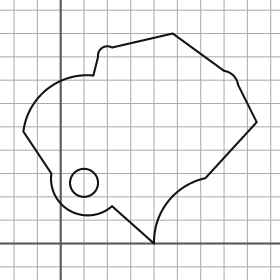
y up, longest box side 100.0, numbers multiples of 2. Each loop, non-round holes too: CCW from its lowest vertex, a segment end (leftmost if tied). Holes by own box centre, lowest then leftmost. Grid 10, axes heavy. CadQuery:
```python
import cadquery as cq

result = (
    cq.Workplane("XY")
    .moveTo(40.0, 0.0)
    .threePointArc((46.0, 18.0), (62.0, 28.0))
    .lineTo(84.0, 52.0)
    .lineTo(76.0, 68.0)
    .threePointArc((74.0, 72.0), (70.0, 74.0))
    .lineTo(48.0, 90.0)
    .lineTo(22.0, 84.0)
    .threePointArc((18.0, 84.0), (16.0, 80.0))
    .lineTo(14.0, 72.0)
    .threePointArc((-6.0, 66.0), (-16.0, 48.0))
    .lineTo(-4.0, 30.0)
    .threePointArc((4.0, 14.0), (22.0, 16.0))
    .close()
    .moveTo(10.0, 26.0)
    .circle(6.0)
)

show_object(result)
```